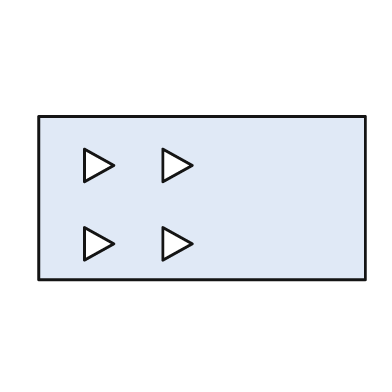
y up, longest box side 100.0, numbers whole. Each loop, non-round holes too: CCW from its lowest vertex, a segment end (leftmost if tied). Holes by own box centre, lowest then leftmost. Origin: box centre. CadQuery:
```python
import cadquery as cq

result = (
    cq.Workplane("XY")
    .moveTo(-50.0, -25.0)
    .lineTo(50.0, -25.0)
    .lineTo(50.0, 25.0)
    .lineTo(-50.0, 25.0)
    .close()
    .moveTo(-36.0, -19.0)
    .lineTo(-27.0, -14.0)
    .lineTo(-36.0, -9.0)
    .close()
    .moveTo(-12.0, -19.0)
    .lineTo(-3.0, -14.0)
    .lineTo(-12.0, -9.0)
    .close()
    .moveTo(-36.0, 5.0)
    .lineTo(-27.0, 10.0)
    .lineTo(-36.0, 15.0)
    .close()
    .moveTo(-12.0, 5.0)
    .lineTo(-3.0, 10.0)
    .lineTo(-12.0, 15.0)
    .close()
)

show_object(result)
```